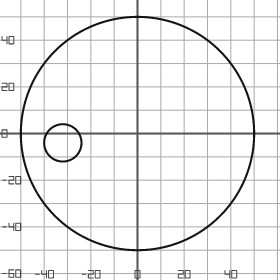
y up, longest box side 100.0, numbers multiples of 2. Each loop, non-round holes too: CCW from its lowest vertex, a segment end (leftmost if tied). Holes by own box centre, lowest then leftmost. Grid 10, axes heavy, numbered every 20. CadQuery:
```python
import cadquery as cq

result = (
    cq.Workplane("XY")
    .moveTo(0.0, 0.0)
    .circle(50.0)
    .moveTo(-32.0, -4.0)
    .circle(8.0)
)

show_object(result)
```